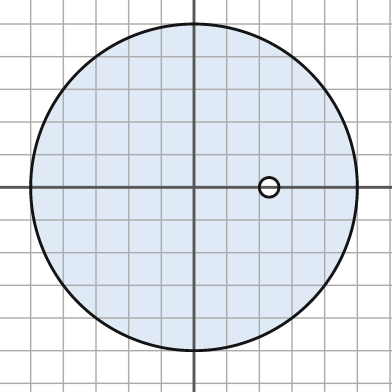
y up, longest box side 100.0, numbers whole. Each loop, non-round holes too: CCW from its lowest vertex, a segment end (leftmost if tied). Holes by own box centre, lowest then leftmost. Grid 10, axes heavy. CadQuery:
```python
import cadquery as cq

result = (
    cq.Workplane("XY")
    .moveTo(0.0, 0.0)
    .circle(50.0)
    .moveTo(23.0, 0.0)
    .circle(3.0)
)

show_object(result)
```